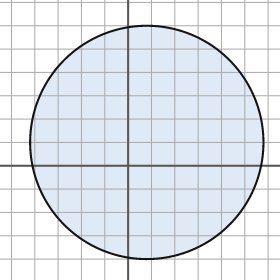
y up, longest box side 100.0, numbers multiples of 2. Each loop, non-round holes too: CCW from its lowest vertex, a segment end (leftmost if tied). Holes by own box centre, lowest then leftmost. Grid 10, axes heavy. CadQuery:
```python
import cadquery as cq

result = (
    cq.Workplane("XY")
    .moveTo(8.0, 10.0)
    .circle(50.0)
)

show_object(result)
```